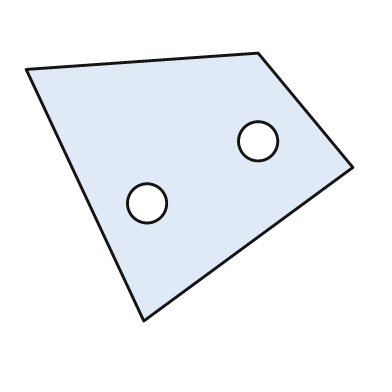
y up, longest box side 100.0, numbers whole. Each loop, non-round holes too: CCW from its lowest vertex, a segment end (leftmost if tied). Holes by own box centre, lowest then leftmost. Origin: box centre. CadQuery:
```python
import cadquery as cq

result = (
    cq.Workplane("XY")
    .moveTo(-14.0, -41.0)
    .lineTo(50.0, 6.0)
    .lineTo(21.0, 41.0)
    .lineTo(-50.0, 36.0)
    .close()
    .moveTo(-13.0, -5.0)
    .circle(6.0)
    .moveTo(21.0, 14.0)
    .circle(6.0)
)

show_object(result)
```